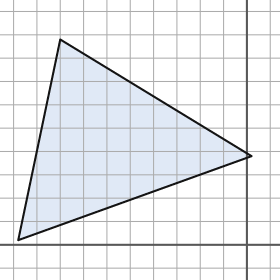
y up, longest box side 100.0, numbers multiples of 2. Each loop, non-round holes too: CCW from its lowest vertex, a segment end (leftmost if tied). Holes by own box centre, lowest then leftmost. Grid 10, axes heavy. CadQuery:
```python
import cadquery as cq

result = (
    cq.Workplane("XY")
    .moveTo(-98.0, 2.0)
    .lineTo(2.0, 38.0)
    .lineTo(-80.0, 88.0)
    .close()
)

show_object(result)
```